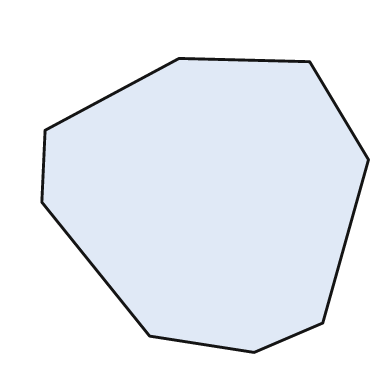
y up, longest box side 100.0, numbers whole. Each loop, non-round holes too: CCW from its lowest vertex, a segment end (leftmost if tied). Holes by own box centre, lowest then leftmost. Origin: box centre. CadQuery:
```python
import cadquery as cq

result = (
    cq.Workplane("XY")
    .moveTo(15.0, -45.0)
    .lineTo(36.0, -36.0)
    .lineTo(50.0, 14.0)
    .lineTo(32.0, 44.0)
    .lineTo(-8.0, 45.0)
    .lineTo(-49.0, 23.0)
    .lineTo(-50.0, 1.0)
    .lineTo(-17.0, -40.0)
    .close()
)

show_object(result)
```